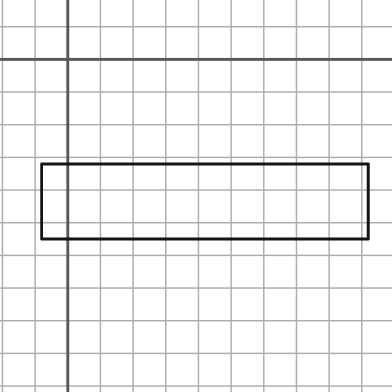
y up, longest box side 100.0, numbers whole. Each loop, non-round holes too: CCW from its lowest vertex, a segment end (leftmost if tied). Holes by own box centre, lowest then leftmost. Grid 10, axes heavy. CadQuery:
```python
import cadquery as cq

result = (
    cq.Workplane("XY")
    .moveTo(-8.0, -55.0)
    .lineTo(92.0, -55.0)
    .lineTo(92.0, -32.0)
    .lineTo(-8.0, -32.0)
    .close()
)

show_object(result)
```